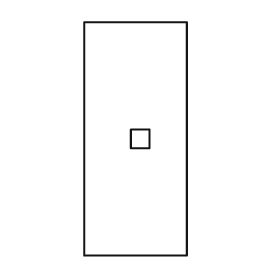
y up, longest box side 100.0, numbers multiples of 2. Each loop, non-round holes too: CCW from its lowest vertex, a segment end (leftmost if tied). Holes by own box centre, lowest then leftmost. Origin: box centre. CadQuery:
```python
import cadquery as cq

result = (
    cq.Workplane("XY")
    .moveTo(-22.0, -50.0)
    .lineTo(22.0, -50.0)
    .lineTo(22.0, 50.0)
    .lineTo(-22.0, 50.0)
    .close()
    .moveTo(-2.0, -4.0)
    .lineTo(6.0, -4.0)
    .lineTo(6.0, 4.0)
    .lineTo(-2.0, 4.0)
    .close()
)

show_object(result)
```